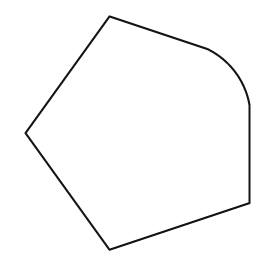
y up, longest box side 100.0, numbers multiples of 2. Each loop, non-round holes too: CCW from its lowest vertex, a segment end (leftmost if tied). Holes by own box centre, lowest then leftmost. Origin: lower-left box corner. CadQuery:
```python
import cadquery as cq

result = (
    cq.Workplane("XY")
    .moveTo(36.0, 0.0)
    .lineTo(96.0, 20.0)
    .lineTo(96.0, 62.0)
    .threePointArc((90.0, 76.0), (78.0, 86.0))
    .lineTo(36.0, 100.0)
    .lineTo(0.0, 50.0)
    .close()
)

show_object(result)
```